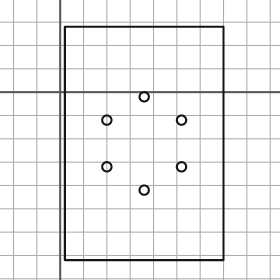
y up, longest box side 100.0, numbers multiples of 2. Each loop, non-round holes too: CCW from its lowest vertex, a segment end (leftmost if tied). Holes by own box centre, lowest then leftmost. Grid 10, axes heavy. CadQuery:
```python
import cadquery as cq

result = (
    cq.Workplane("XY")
    .moveTo(2.0, -72.0)
    .lineTo(70.0, -72.0)
    .lineTo(70.0, 28.0)
    .lineTo(2.0, 28.0)
    .close()
    .moveTo(36.0, -42.0)
    .circle(2.0)
    .moveTo(20.0, -32.0)
    .circle(2.0)
    .moveTo(52.0, -32.0)
    .circle(2.0)
    .moveTo(20.0, -12.0)
    .circle(2.0)
    .moveTo(52.0, -12.0)
    .circle(2.0)
    .moveTo(36.0, -2.0)
    .circle(2.0)
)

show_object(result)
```